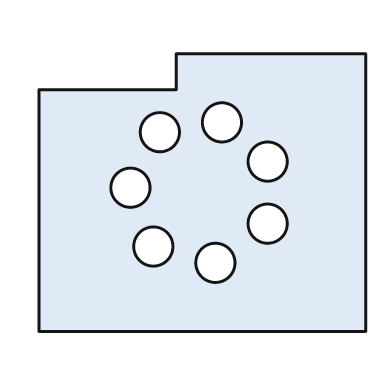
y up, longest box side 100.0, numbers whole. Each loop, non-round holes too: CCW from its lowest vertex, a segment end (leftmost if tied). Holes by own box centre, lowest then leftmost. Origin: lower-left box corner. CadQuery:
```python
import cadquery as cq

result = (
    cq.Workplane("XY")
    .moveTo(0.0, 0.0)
    .lineTo(100.0, 0.0)
    .lineTo(100.0, 85.0)
    .lineTo(42.0, 85.0)
    .lineTo(42.0, 74.0)
    .lineTo(0.0, 74.0)
    .close()
    .moveTo(54.0, 21.0)
    .circle(6.0)
    .moveTo(35.0, 26.0)
    .circle(6.0)
    .moveTo(70.0, 33.0)
    .circle(6.0)
    .moveTo(28.0, 44.0)
    .circle(6.0)
    .moveTo(70.0, 52.0)
    .circle(6.0)
    .moveTo(37.0, 61.0)
    .circle(6.0)
    .moveTo(56.0, 64.0)
    .circle(6.0)
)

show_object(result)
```